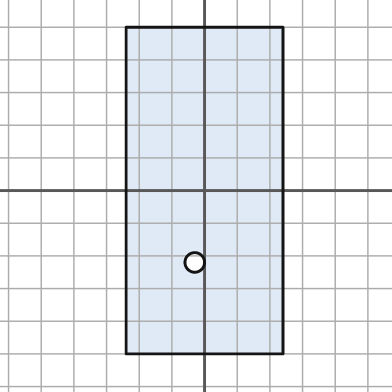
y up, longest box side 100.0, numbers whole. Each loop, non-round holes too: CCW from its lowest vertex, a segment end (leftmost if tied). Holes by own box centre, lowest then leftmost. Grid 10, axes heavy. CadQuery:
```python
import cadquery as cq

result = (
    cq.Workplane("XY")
    .moveTo(-24.0, -50.0)
    .lineTo(24.0, -50.0)
    .lineTo(24.0, 50.0)
    .lineTo(-24.0, 50.0)
    .close()
    .moveTo(-3.0, -22.0)
    .circle(3.0)
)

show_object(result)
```